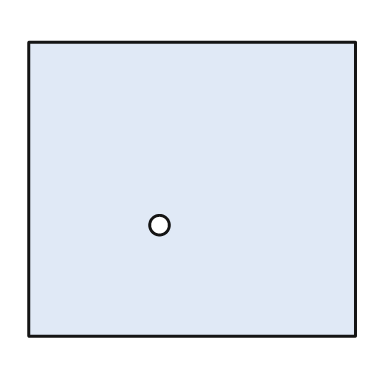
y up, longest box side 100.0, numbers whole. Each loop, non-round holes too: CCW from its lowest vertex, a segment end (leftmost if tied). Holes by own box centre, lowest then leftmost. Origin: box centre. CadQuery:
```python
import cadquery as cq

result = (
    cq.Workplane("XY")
    .moveTo(-50.0, -45.0)
    .lineTo(50.0, -45.0)
    .lineTo(50.0, 45.0)
    .lineTo(-50.0, 45.0)
    .close()
    .moveTo(-10.0, -11.0)
    .circle(3.0)
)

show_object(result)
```